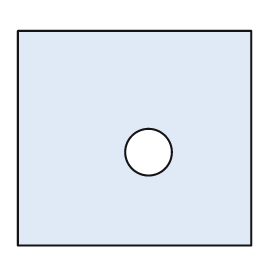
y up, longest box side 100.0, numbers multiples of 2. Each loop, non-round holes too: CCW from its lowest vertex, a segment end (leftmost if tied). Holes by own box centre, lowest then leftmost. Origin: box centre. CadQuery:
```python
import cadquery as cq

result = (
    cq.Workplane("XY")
    .moveTo(-50.0, -46.0)
    .lineTo(50.0, -46.0)
    .lineTo(50.0, 46.0)
    .lineTo(-50.0, 46.0)
    .close()
    .moveTo(6.0, -6.0)
    .circle(10.0)
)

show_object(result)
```